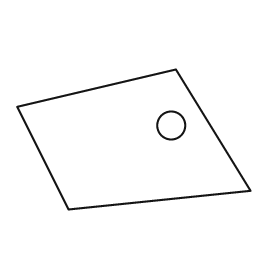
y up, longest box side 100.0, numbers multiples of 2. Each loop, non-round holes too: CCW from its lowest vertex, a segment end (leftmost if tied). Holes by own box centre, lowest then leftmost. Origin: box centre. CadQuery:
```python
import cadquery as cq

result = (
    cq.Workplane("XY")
    .moveTo(-28.0, -30.0)
    .lineTo(50.0, -22.0)
    .lineTo(18.0, 30.0)
    .lineTo(-50.0, 14.0)
    .close()
    .moveTo(16.0, 6.0)
    .circle(6.0)
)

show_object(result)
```